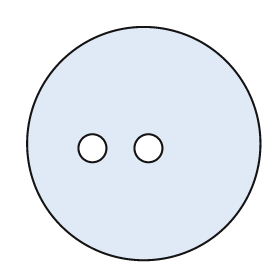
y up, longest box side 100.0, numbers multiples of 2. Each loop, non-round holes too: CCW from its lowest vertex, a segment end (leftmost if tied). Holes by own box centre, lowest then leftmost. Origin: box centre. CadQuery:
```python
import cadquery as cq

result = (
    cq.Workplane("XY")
    .moveTo(0.0, 0.0)
    .circle(50.0)
    .moveTo(-22.0, -2.0)
    .circle(6.0)
    .moveTo(2.0, -2.0)
    .circle(6.0)
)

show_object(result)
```